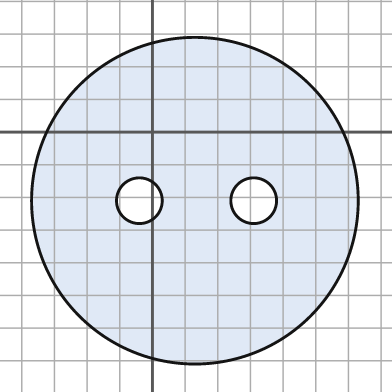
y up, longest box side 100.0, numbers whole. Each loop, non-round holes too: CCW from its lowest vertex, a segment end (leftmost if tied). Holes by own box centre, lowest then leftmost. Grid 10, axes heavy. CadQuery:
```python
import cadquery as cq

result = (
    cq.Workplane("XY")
    .moveTo(13.0, -21.0)
    .circle(50.0)
    .moveTo(-4.0, -21.0)
    .circle(7.0)
    .moveTo(31.0, -21.0)
    .circle(7.0)
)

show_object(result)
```